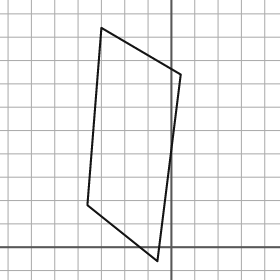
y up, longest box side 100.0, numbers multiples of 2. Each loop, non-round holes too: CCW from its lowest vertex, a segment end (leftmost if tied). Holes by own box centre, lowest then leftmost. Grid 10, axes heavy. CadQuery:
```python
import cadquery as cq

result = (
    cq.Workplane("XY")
    .moveTo(-6.0, -6.0)
    .lineTo(4.0, 74.0)
    .lineTo(-30.0, 94.0)
    .lineTo(-36.0, 18.0)
    .close()
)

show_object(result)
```